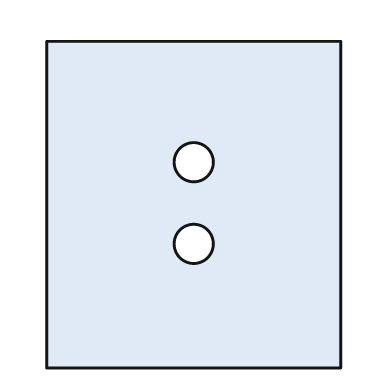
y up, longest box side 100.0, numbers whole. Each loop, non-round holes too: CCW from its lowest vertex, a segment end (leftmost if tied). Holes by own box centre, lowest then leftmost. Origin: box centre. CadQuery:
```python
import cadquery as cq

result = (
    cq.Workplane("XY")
    .moveTo(-45.0, -50.0)
    .lineTo(45.0, -50.0)
    .lineTo(45.0, 50.0)
    .lineTo(-45.0, 50.0)
    .close()
    .moveTo(0.0, -12.0)
    .circle(6.0)
    .moveTo(0.0, 13.0)
    .circle(6.0)
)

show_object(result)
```